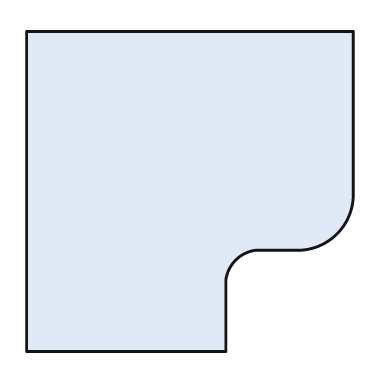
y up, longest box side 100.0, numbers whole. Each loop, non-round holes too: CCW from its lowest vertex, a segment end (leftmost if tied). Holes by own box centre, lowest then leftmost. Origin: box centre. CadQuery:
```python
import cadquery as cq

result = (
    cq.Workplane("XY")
    .moveTo(-50.0, -49.0)
    .lineTo(11.0, -49.0)
    .lineTo(11.0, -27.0)
    .threePointArc((14.0, -21.0), (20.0, -18.0))
    .lineTo(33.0, -18.0)
    .threePointArc((45.0, -13.0), (50.0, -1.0))
    .lineTo(50.0, 49.0)
    .lineTo(-50.0, 49.0)
    .close()
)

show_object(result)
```